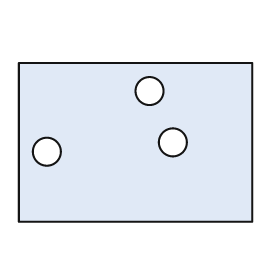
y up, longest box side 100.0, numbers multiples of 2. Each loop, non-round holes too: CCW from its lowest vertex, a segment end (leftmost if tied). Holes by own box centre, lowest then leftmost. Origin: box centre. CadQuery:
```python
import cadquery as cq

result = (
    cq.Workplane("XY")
    .moveTo(-50.0, -34.0)
    .lineTo(50.0, -34.0)
    .lineTo(50.0, 34.0)
    .lineTo(-50.0, 34.0)
    .close()
    .moveTo(-38.0, -4.0)
    .circle(6.0)
    .moveTo(16.0, 0.0)
    .circle(6.0)
    .moveTo(6.0, 22.0)
    .circle(6.0)
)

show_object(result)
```